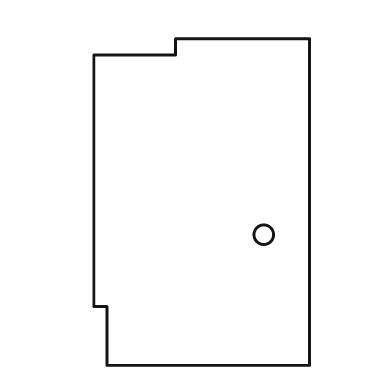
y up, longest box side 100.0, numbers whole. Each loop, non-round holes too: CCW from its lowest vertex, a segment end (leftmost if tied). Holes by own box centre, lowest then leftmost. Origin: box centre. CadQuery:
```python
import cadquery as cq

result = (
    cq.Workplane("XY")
    .moveTo(-29.0, -50.0)
    .lineTo(33.0, -50.0)
    .lineTo(33.0, 50.0)
    .lineTo(-8.0, 50.0)
    .lineTo(-8.0, 45.0)
    .lineTo(-33.0, 45.0)
    .lineTo(-33.0, -32.0)
    .lineTo(-29.0, -32.0)
    .close()
    .moveTo(19.0, -10.0)
    .circle(3.0)
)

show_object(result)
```